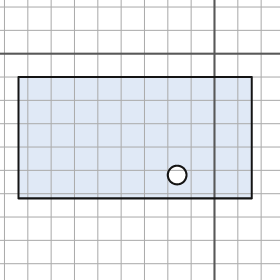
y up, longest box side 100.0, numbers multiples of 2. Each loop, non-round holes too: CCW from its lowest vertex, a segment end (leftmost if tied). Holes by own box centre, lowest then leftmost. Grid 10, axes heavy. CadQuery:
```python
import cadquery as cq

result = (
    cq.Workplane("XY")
    .moveTo(-84.0, -62.0)
    .lineTo(16.0, -62.0)
    .lineTo(16.0, -10.0)
    .lineTo(-84.0, -10.0)
    .close()
    .moveTo(-16.0, -52.0)
    .circle(4.0)
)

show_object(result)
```